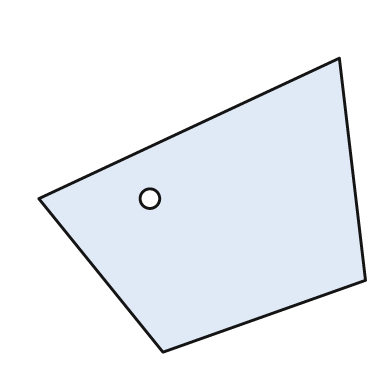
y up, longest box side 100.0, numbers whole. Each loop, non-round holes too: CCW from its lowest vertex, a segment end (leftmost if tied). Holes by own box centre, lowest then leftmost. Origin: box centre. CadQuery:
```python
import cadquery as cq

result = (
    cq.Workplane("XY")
    .moveTo(-12.0, -45.0)
    .lineTo(50.0, -23.0)
    .lineTo(42.0, 45.0)
    .lineTo(-50.0, 2.0)
    .close()
    .moveTo(-16.0, 2.0)
    .circle(3.0)
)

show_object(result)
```